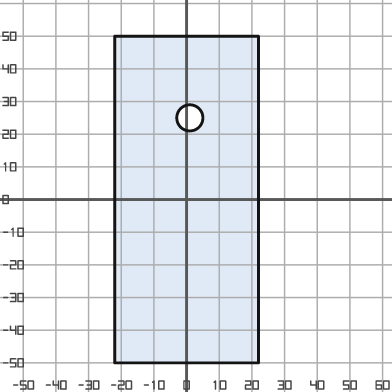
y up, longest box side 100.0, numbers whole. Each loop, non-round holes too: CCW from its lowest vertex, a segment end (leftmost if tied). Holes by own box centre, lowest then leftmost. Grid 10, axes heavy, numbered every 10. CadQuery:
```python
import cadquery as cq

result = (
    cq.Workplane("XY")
    .moveTo(-22.0, -50.0)
    .lineTo(22.0, -50.0)
    .lineTo(22.0, 50.0)
    .lineTo(-22.0, 50.0)
    .close()
    .moveTo(1.0, 25.0)
    .circle(4.0)
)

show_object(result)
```